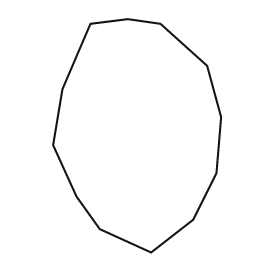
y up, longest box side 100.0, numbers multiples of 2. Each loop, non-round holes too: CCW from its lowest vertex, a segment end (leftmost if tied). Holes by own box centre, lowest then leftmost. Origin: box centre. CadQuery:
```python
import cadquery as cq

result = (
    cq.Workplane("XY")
    .moveTo(6.0, -50.0)
    .lineTo(24.0, -36.0)
    .lineTo(34.0, -16.0)
    .lineTo(36.0, 8.0)
    .lineTo(30.0, 30.0)
    .lineTo(10.0, 48.0)
    .lineTo(-4.0, 50.0)
    .lineTo(-20.0, 48.0)
    .lineTo(-32.0, 20.0)
    .lineTo(-36.0, -4.0)
    .lineTo(-26.0, -26.0)
    .lineTo(-16.0, -40.0)
    .close()
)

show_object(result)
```